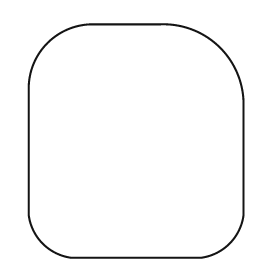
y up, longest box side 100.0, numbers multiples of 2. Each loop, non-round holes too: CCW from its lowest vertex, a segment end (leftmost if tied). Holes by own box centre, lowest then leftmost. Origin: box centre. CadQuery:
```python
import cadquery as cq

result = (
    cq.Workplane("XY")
    .moveTo(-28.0, -50.0)
    .lineTo(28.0, -50.0)
    .threePointArc((40.0, -44.0), (46.0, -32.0))
    .lineTo(46.0, 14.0)
    .threePointArc((36.0, 40.0), (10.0, 50.0))
    .lineTo(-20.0, 50.0)
    .threePointArc((-38.0, 42.0), (-46.0, 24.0))
    .lineTo(-46.0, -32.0)
    .threePointArc((-40.0, -44.0), (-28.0, -50.0))
    .close()
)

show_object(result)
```